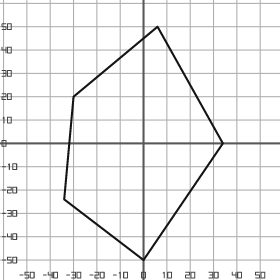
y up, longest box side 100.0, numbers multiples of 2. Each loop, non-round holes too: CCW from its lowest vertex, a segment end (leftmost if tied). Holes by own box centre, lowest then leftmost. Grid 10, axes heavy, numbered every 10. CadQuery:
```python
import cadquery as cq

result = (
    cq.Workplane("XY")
    .moveTo(0.0, -50.0)
    .lineTo(34.0, 0.0)
    .lineTo(6.0, 50.0)
    .lineTo(-30.0, 20.0)
    .lineTo(-34.0, -24.0)
    .close()
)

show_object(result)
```